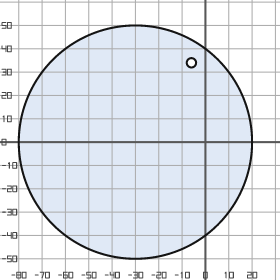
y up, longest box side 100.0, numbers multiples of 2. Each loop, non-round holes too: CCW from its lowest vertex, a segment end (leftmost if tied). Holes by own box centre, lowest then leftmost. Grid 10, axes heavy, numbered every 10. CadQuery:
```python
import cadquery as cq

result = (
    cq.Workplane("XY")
    .moveTo(-30.0, 0.0)
    .circle(50.0)
    .moveTo(-6.0, 34.0)
    .circle(2.0)
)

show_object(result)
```